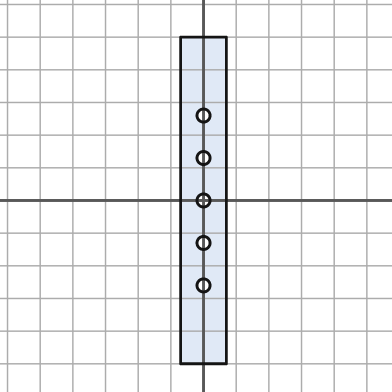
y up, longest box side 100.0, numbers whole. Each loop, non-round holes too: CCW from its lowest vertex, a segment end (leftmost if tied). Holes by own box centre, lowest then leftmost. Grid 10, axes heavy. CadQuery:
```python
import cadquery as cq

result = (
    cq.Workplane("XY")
    .moveTo(-7.0, -50.0)
    .lineTo(7.0, -50.0)
    .lineTo(7.0, 50.0)
    .lineTo(-7.0, 50.0)
    .close()
    .moveTo(0.0, -26.0)
    .circle(2.0)
    .moveTo(0.0, -13.0)
    .circle(2.0)
    .moveTo(0.0, 0.0)
    .circle(2.0)
    .moveTo(0.0, 13.0)
    .circle(2.0)
    .moveTo(0.0, 26.0)
    .circle(2.0)
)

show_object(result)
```